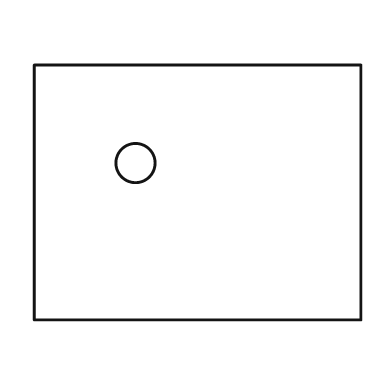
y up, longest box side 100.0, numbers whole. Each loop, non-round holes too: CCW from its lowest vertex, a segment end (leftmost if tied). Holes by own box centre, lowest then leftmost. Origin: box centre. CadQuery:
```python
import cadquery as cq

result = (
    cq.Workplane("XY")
    .moveTo(-50.0, -39.0)
    .lineTo(50.0, -39.0)
    .lineTo(50.0, 39.0)
    .lineTo(-50.0, 39.0)
    .close()
    .moveTo(-19.0, 9.0)
    .circle(6.0)
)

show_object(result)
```